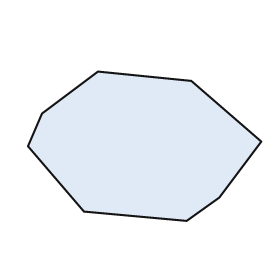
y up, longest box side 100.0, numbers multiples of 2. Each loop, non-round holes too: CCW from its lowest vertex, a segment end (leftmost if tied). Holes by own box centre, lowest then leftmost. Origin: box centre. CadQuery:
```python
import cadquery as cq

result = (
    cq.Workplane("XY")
    .moveTo(18.0, -32.0)
    .lineTo(32.0, -22.0)
    .lineTo(50.0, 2.0)
    .lineTo(20.0, 28.0)
    .lineTo(-20.0, 32.0)
    .lineTo(-44.0, 14.0)
    .lineTo(-50.0, 0.0)
    .lineTo(-26.0, -28.0)
    .close()
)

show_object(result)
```